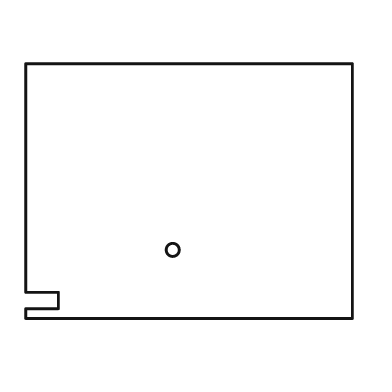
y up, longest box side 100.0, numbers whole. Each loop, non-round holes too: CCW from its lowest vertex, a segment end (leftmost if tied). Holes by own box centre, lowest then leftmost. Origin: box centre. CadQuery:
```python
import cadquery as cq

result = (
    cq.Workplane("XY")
    .moveTo(-50.0, -39.0)
    .lineTo(50.0, -39.0)
    .lineTo(50.0, 39.0)
    .lineTo(-50.0, 39.0)
    .lineTo(-50.0, -31.0)
    .lineTo(-40.0, -31.0)
    .lineTo(-40.0, -36.0)
    .lineTo(-50.0, -36.0)
    .close()
    .moveTo(-5.0, -18.0)
    .circle(2.0)
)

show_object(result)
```